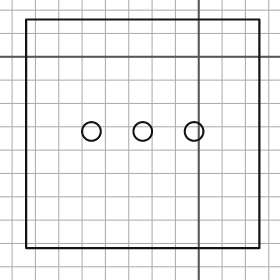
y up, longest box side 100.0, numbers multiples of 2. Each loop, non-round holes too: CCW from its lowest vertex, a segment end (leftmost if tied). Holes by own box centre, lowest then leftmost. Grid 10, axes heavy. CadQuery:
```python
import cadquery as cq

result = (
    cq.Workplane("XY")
    .moveTo(-74.0, -82.0)
    .lineTo(26.0, -82.0)
    .lineTo(26.0, 16.0)
    .lineTo(-74.0, 16.0)
    .close()
    .moveTo(-46.0, -32.0)
    .circle(4.0)
    .moveTo(-24.0, -32.0)
    .circle(4.0)
    .moveTo(-2.0, -32.0)
    .circle(4.0)
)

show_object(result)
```